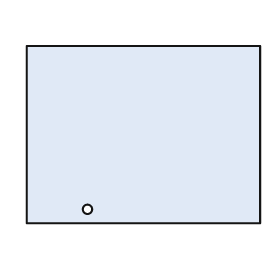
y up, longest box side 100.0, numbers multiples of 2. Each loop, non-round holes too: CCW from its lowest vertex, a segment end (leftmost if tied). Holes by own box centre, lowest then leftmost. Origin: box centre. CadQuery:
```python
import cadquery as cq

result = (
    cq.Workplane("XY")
    .moveTo(-50.0, -38.0)
    .lineTo(50.0, -38.0)
    .lineTo(50.0, 38.0)
    .lineTo(-50.0, 38.0)
    .close()
    .moveTo(-24.0, -32.0)
    .circle(2.0)
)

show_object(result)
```